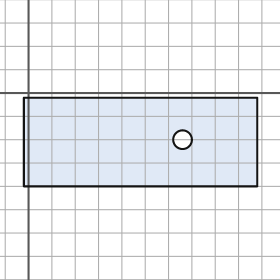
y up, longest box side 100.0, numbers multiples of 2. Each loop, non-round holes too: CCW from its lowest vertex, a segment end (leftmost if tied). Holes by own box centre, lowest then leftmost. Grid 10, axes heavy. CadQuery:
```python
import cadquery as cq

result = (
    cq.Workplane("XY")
    .moveTo(-2.0, -40.0)
    .lineTo(98.0, -40.0)
    .lineTo(98.0, -2.0)
    .lineTo(-2.0, -2.0)
    .close()
    .moveTo(66.0, -20.0)
    .circle(4.0)
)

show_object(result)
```